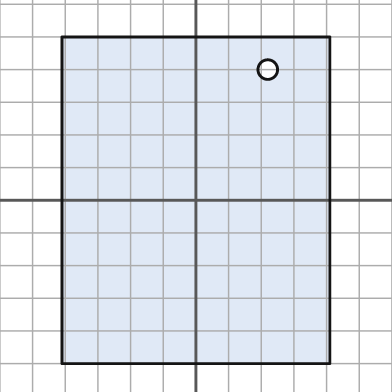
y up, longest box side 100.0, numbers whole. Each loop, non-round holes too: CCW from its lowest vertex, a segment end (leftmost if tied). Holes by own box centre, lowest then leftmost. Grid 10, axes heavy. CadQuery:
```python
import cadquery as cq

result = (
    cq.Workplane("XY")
    .moveTo(-41.0, -50.0)
    .lineTo(41.0, -50.0)
    .lineTo(41.0, 50.0)
    .lineTo(-41.0, 50.0)
    .close()
    .moveTo(22.0, 40.0)
    .circle(3.0)
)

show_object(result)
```